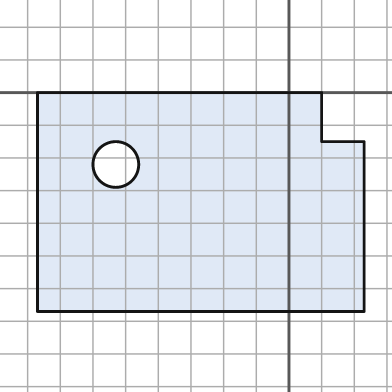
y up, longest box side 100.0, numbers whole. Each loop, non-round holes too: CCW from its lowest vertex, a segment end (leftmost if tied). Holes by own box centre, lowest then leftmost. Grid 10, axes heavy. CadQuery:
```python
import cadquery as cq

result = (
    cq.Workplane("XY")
    .moveTo(-77.0, -67.0)
    .lineTo(23.0, -67.0)
    .lineTo(23.0, -15.0)
    .lineTo(10.0, -15.0)
    .lineTo(10.0, 0.0)
    .lineTo(-77.0, 0.0)
    .close()
    .moveTo(-53.0, -22.0)
    .circle(7.0)
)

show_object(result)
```